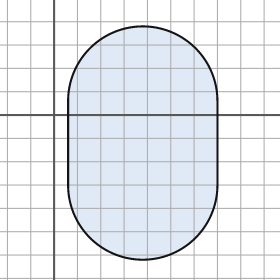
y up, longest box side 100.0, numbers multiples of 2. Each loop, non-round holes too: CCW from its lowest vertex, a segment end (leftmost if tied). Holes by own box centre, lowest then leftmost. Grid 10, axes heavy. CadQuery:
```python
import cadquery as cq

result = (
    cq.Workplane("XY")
    .moveTo(6.0, -30.0)
    .threePointArc((38.0, -62.0), (70.0, -30.0))
    .lineTo(70.0, 6.0)
    .threePointArc((38.0, 38.0), (6.0, 6.0))
    .close()
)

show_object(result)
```